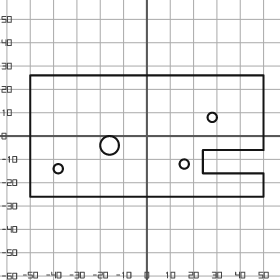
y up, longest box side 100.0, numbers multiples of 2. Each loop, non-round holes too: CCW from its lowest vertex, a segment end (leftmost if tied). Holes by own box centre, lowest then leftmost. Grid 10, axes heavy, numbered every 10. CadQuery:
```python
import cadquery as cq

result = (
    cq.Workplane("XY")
    .moveTo(-50.0, -26.0)
    .lineTo(50.0, -26.0)
    .lineTo(50.0, -16.0)
    .lineTo(24.0, -16.0)
    .lineTo(24.0, -6.0)
    .lineTo(50.0, -6.0)
    .lineTo(50.0, 26.0)
    .lineTo(-50.0, 26.0)
    .close()
    .moveTo(-38.0, -14.0)
    .circle(2.0)
    .moveTo(16.0, -12.0)
    .circle(2.0)
    .moveTo(-16.0, -4.0)
    .circle(4.0)
    .moveTo(28.0, 8.0)
    .circle(2.0)
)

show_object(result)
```